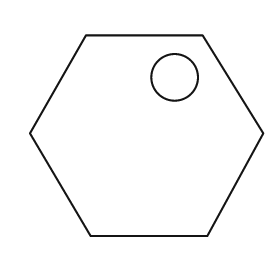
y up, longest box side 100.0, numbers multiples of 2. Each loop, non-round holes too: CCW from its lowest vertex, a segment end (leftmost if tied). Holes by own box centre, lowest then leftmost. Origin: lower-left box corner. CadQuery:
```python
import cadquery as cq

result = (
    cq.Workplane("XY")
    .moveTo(26.0, 0.0)
    .lineTo(76.0, 0.0)
    .lineTo(100.0, 44.0)
    .lineTo(74.0, 86.0)
    .lineTo(24.0, 86.0)
    .lineTo(0.0, 44.0)
    .close()
    .moveTo(62.0, 68.0)
    .circle(10.0)
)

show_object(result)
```